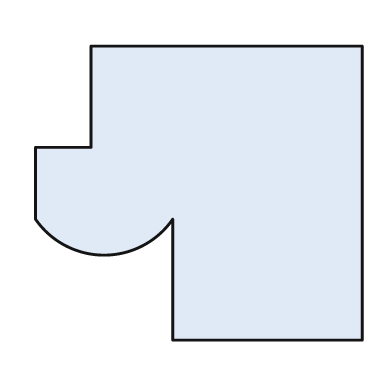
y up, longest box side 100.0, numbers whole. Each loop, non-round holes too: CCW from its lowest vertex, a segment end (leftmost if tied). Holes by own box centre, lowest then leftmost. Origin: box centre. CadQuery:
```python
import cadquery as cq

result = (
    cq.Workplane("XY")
    .moveTo(-8.0, -45.0)
    .lineTo(50.0, -45.0)
    .lineTo(50.0, 45.0)
    .lineTo(-33.0, 45.0)
    .lineTo(-33.0, 14.0)
    .lineTo(-50.0, 14.0)
    .lineTo(-50.0, -8.0)
    .threePointArc((-29.0, -19.0), (-8.0, -8.0))
    .close()
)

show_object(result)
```